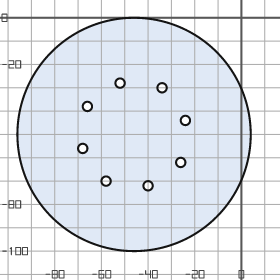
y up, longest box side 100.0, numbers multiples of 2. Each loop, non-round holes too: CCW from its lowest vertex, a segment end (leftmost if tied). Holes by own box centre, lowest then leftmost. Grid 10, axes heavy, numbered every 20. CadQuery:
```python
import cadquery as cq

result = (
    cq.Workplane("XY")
    .moveTo(-46.0, -50.0)
    .circle(50.0)
    .moveTo(-40.0, -72.0)
    .circle(2.0)
    .moveTo(-58.0, -70.0)
    .circle(2.0)
    .moveTo(-26.0, -62.0)
    .circle(2.0)
    .moveTo(-68.0, -56.0)
    .circle(2.0)
    .moveTo(-24.0, -44.0)
    .circle(2.0)
    .moveTo(-66.0, -38.0)
    .circle(2.0)
    .moveTo(-34.0, -30.0)
    .circle(2.0)
    .moveTo(-52.0, -28.0)
    .circle(2.0)
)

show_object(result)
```